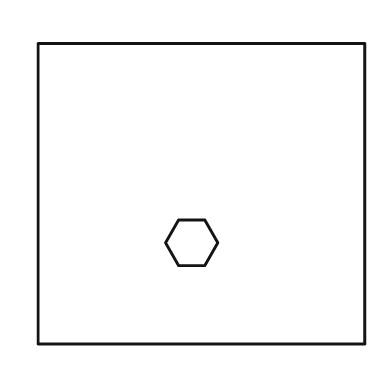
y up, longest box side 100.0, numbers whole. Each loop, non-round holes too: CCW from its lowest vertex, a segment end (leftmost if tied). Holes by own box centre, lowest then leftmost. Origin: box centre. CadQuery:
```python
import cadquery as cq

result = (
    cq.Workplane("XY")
    .moveTo(-50.0, -46.0)
    .lineTo(50.0, -46.0)
    .lineTo(50.0, 46.0)
    .lineTo(-50.0, 46.0)
    .close()
    .moveTo(-7.0, -22.0)
    .lineTo(1.0, -22.0)
    .lineTo(5.0, -15.0)
    .lineTo(1.0, -8.0)
    .lineTo(-7.0, -8.0)
    .lineTo(-11.0, -15.0)
    .close()
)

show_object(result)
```